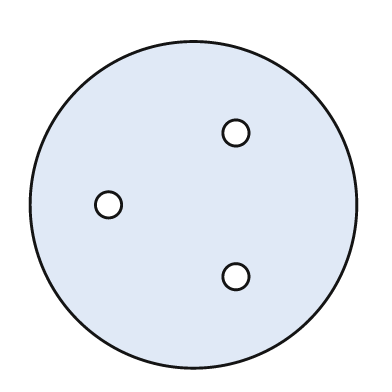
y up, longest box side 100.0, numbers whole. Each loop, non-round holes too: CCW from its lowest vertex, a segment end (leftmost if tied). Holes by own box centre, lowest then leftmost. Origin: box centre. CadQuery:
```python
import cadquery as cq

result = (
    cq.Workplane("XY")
    .moveTo(0.0, 0.0)
    .circle(50.0)
    .moveTo(13.0, -22.0)
    .circle(4.0)
    .moveTo(-26.0, 0.0)
    .circle(4.0)
    .moveTo(13.0, 22.0)
    .circle(4.0)
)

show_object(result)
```